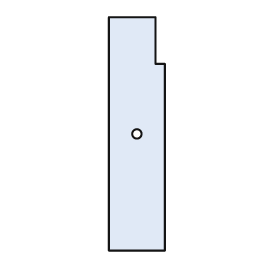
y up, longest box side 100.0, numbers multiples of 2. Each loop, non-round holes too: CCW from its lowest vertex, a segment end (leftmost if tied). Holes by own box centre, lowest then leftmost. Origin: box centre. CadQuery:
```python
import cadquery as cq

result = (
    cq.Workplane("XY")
    .moveTo(-12.0, -50.0)
    .lineTo(12.0, -50.0)
    .lineTo(12.0, 30.0)
    .lineTo(8.0, 30.0)
    .lineTo(8.0, 50.0)
    .lineTo(-12.0, 50.0)
    .close()
    .moveTo(0.0, 0.0)
    .circle(2.0)
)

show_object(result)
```